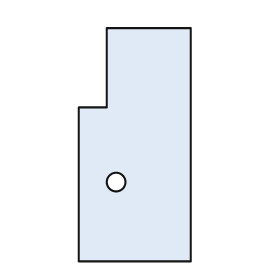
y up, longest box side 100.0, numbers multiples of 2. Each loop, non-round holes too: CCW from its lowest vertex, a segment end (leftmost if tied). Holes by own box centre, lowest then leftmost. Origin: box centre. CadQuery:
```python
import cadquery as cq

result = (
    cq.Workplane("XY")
    .moveTo(-24.0, -50.0)
    .lineTo(24.0, -50.0)
    .lineTo(24.0, 50.0)
    .lineTo(-12.0, 50.0)
    .lineTo(-12.0, 16.0)
    .lineTo(-24.0, 16.0)
    .close()
    .moveTo(-8.0, -16.0)
    .circle(4.0)
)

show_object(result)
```